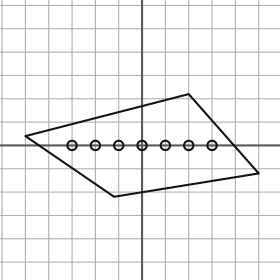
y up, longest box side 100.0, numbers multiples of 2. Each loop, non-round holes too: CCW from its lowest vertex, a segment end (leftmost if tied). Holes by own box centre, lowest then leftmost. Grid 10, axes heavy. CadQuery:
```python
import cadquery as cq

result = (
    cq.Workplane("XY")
    .moveTo(-12.0, -22.0)
    .lineTo(50.0, -12.0)
    .lineTo(20.0, 22.0)
    .lineTo(-50.0, 4.0)
    .close()
    .moveTo(-30.0, 0.0)
    .circle(2.0)
    .moveTo(-20.0, 0.0)
    .circle(2.0)
    .moveTo(-10.0, 0.0)
    .circle(2.0)
    .moveTo(0.0, 0.0)
    .circle(2.0)
    .moveTo(10.0, 0.0)
    .circle(2.0)
    .moveTo(20.0, 0.0)
    .circle(2.0)
    .moveTo(30.0, 0.0)
    .circle(2.0)
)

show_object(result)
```